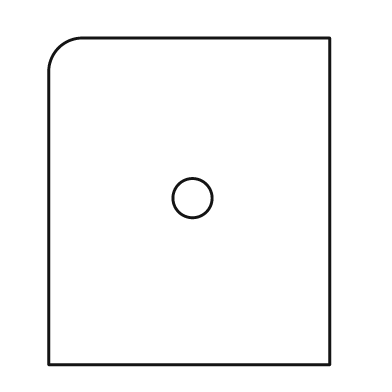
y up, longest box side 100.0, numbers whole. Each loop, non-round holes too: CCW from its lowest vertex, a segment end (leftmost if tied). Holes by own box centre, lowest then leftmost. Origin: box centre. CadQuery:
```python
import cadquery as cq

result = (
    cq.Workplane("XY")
    .moveTo(-43.0, -50.0)
    .lineTo(43.0, -50.0)
    .lineTo(43.0, 50.0)
    .lineTo(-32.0, 50.0)
    .threePointArc((-40.0, 47.0), (-43.0, 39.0))
    .close()
    .moveTo(1.0, 1.0)
    .circle(6.0)
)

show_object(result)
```